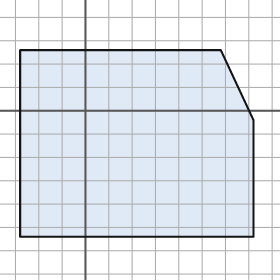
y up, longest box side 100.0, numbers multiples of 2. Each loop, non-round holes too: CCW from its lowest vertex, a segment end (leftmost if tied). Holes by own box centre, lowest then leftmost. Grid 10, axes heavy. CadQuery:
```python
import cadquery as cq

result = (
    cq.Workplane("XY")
    .moveTo(-28.0, -54.0)
    .lineTo(72.0, -54.0)
    .lineTo(72.0, -4.0)
    .lineTo(58.0, 26.0)
    .lineTo(-28.0, 26.0)
    .close()
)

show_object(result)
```